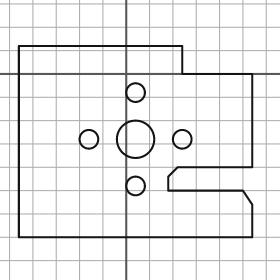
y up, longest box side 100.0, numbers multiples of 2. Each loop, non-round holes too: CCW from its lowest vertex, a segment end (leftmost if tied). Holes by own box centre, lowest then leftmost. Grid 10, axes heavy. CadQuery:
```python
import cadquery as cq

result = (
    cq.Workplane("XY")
    .moveTo(-46.0, -70.0)
    .lineTo(54.0, -70.0)
    .lineTo(54.0, -56.0)
    .lineTo(50.0, -50.0)
    .lineTo(18.0, -50.0)
    .lineTo(18.0, -44.0)
    .lineTo(22.0, -40.0)
    .lineTo(54.0, -40.0)
    .lineTo(54.0, 0.0)
    .lineTo(24.0, 0.0)
    .lineTo(24.0, 12.0)
    .lineTo(-46.0, 12.0)
    .close()
    .moveTo(4.0, -48.0)
    .circle(4.0)
    .moveTo(-16.0, -28.0)
    .circle(4.0)
    .moveTo(4.0, -28.0)
    .circle(8.0)
    .moveTo(24.0, -28.0)
    .circle(4.0)
    .moveTo(4.0, -8.0)
    .circle(4.0)
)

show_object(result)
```